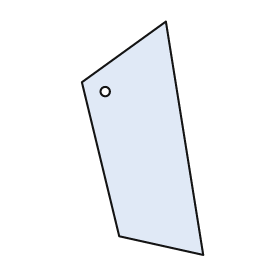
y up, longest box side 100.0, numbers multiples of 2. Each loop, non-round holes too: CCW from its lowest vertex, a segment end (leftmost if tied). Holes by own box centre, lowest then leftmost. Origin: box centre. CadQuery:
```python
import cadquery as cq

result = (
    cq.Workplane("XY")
    .moveTo(26.0, -50.0)
    .lineTo(10.0, 50.0)
    .lineTo(-26.0, 24.0)
    .lineTo(-10.0, -42.0)
    .close()
    .moveTo(-16.0, 20.0)
    .circle(2.0)
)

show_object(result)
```